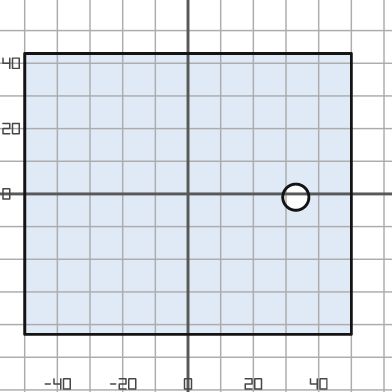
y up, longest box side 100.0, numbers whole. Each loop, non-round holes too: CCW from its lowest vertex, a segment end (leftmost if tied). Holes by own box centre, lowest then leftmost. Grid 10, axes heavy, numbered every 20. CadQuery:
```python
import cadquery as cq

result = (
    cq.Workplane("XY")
    .moveTo(-50.0, -43.0)
    .lineTo(50.0, -43.0)
    .lineTo(50.0, 43.0)
    .lineTo(-50.0, 43.0)
    .close()
    .moveTo(33.0, -1.0)
    .circle(4.0)
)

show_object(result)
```